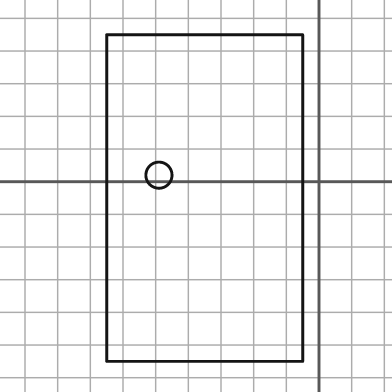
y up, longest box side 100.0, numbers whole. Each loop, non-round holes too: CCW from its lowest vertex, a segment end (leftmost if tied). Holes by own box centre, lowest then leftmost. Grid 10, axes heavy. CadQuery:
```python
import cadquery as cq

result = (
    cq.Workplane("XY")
    .moveTo(-65.0, -55.0)
    .lineTo(-5.0, -55.0)
    .lineTo(-5.0, 45.0)
    .lineTo(-65.0, 45.0)
    .close()
    .moveTo(-49.0, 2.0)
    .circle(4.0)
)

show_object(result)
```